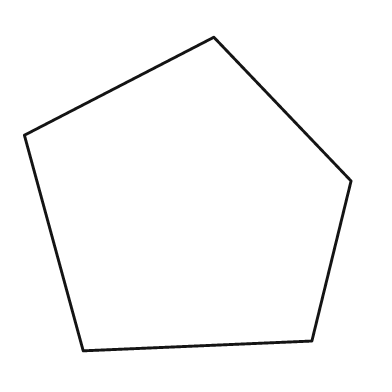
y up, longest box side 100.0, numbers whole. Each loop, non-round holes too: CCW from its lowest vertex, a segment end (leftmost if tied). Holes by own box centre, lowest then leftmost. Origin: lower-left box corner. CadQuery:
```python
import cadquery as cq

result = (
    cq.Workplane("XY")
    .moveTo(18.0, 0.0)
    .lineTo(88.0, 3.0)
    .lineTo(100.0, 52.0)
    .lineTo(58.0, 96.0)
    .lineTo(0.0, 66.0)
    .close()
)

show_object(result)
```